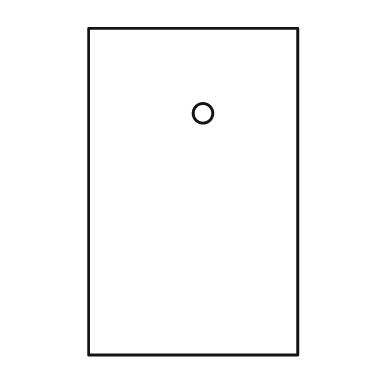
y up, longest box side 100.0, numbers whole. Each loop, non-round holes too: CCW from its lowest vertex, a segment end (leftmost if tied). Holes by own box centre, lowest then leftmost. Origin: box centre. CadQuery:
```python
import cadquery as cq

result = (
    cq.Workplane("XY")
    .moveTo(-32.0, -50.0)
    .lineTo(32.0, -50.0)
    .lineTo(32.0, 50.0)
    .lineTo(-32.0, 50.0)
    .close()
    .moveTo(3.0, 24.0)
    .circle(3.0)
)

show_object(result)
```